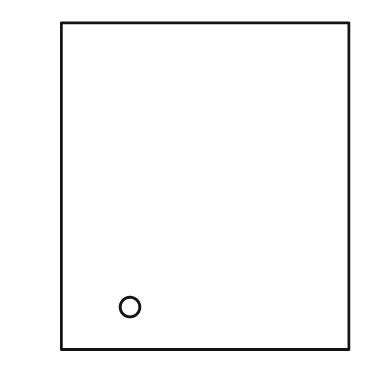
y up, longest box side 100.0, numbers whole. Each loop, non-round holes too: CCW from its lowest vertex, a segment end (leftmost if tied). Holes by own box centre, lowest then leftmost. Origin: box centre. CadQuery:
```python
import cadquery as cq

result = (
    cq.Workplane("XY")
    .moveTo(-44.0, -50.0)
    .lineTo(44.0, -50.0)
    .lineTo(44.0, 50.0)
    .lineTo(-44.0, 50.0)
    .close()
    .moveTo(-23.0, -37.0)
    .circle(3.0)
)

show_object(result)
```